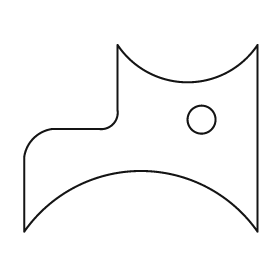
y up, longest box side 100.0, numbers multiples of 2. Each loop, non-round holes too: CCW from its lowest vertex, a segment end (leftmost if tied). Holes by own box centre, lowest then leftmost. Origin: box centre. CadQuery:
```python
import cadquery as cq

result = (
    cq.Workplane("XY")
    .moveTo(-50.0, -40.0)
    .threePointArc((0.0, -14.0), (50.0, -40.0))
    .lineTo(50.0, 40.0)
    .threePointArc((20.0, 24.0), (-10.0, 40.0))
    .lineTo(-10.0, 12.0)
    .threePointArc((-12.0, 6.0), (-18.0, 4.0))
    .lineTo(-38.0, 4.0)
    .threePointArc((-46.0, 0.0), (-50.0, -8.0))
    .close()
    .moveTo(26.0, 8.0)
    .circle(6.0)
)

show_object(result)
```